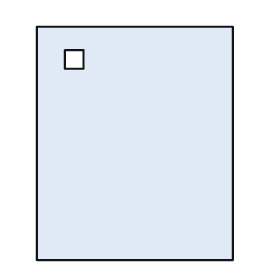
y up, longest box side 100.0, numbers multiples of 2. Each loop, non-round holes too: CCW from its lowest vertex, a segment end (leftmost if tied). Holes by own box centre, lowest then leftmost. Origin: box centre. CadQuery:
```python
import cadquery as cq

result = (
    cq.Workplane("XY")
    .moveTo(-42.0, -50.0)
    .lineTo(42.0, -50.0)
    .lineTo(42.0, 50.0)
    .lineTo(-42.0, 50.0)
    .close()
    .moveTo(-30.0, 32.0)
    .lineTo(-22.0, 32.0)
    .lineTo(-22.0, 40.0)
    .lineTo(-30.0, 40.0)
    .close()
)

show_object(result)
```